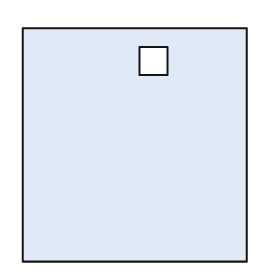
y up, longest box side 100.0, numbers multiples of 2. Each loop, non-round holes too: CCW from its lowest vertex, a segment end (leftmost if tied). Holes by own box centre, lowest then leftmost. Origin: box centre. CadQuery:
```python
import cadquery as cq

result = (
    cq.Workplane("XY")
    .moveTo(-48.0, -50.0)
    .lineTo(48.0, -50.0)
    .lineTo(48.0, 50.0)
    .lineTo(-48.0, 50.0)
    .close()
    .moveTo(2.0, 30.0)
    .lineTo(14.0, 30.0)
    .lineTo(14.0, 42.0)
    .lineTo(2.0, 42.0)
    .close()
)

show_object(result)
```